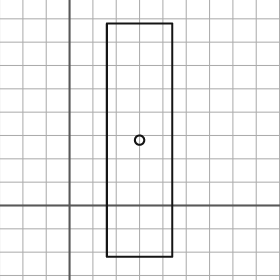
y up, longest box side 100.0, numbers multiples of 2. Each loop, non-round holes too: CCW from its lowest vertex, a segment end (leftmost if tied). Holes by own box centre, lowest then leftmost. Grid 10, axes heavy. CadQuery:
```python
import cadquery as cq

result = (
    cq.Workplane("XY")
    .moveTo(16.0, -22.0)
    .lineTo(44.0, -22.0)
    .lineTo(44.0, 78.0)
    .lineTo(16.0, 78.0)
    .close()
    .moveTo(30.0, 28.0)
    .circle(2.0)
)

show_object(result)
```